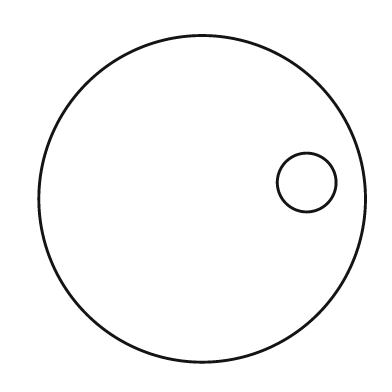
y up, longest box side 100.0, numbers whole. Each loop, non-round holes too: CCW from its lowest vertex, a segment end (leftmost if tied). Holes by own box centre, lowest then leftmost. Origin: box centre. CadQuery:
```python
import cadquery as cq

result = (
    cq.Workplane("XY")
    .moveTo(0.0, 0.0)
    .circle(50.0)
    .moveTo(32.0, 5.0)
    .circle(9.0)
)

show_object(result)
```